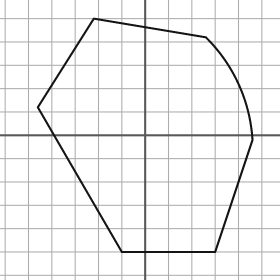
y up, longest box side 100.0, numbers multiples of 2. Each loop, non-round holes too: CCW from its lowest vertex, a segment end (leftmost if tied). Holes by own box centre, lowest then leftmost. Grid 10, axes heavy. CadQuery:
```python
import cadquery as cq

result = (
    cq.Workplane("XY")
    .moveTo(-10.0, -50.0)
    .lineTo(30.0, -50.0)
    .lineTo(46.0, -2.0)
    .threePointArc((40.0, 22.0), (26.0, 42.0))
    .lineTo(-22.0, 50.0)
    .lineTo(-46.0, 12.0)
    .close()
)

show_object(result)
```